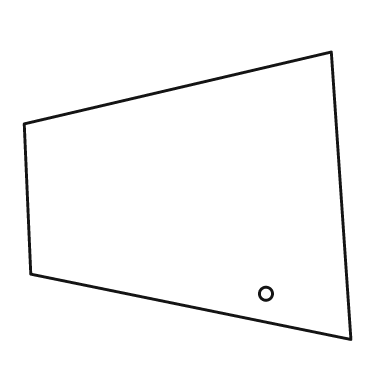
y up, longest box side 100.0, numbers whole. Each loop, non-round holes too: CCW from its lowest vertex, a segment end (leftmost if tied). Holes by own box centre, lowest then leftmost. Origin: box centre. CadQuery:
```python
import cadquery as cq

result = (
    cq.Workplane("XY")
    .moveTo(50.0, -44.0)
    .lineTo(44.0, 44.0)
    .lineTo(-50.0, 22.0)
    .lineTo(-48.0, -24.0)
    .close()
    .moveTo(24.0, -30.0)
    .circle(2.0)
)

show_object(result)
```